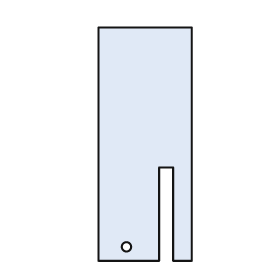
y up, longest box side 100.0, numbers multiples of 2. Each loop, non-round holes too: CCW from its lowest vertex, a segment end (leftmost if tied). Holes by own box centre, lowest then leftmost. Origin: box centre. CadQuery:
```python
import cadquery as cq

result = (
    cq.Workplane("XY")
    .moveTo(-20.0, -50.0)
    .lineTo(6.0, -50.0)
    .lineTo(6.0, -10.0)
    .lineTo(12.0, -10.0)
    .lineTo(12.0, -50.0)
    .lineTo(20.0, -50.0)
    .lineTo(20.0, 50.0)
    .lineTo(-20.0, 50.0)
    .close()
    .moveTo(-8.0, -44.0)
    .circle(2.0)
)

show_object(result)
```